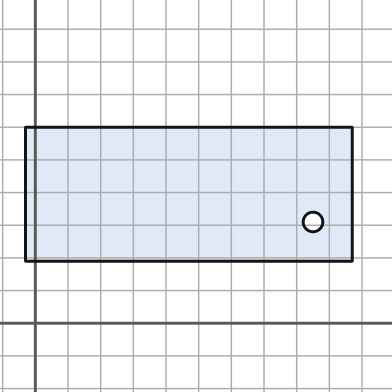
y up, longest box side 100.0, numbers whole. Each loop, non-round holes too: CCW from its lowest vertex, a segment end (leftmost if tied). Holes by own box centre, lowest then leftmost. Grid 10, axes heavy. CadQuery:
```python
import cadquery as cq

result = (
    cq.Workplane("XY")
    .moveTo(-3.0, 19.0)
    .lineTo(97.0, 19.0)
    .lineTo(97.0, 60.0)
    .lineTo(-3.0, 60.0)
    .close()
    .moveTo(85.0, 31.0)
    .circle(3.0)
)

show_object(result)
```